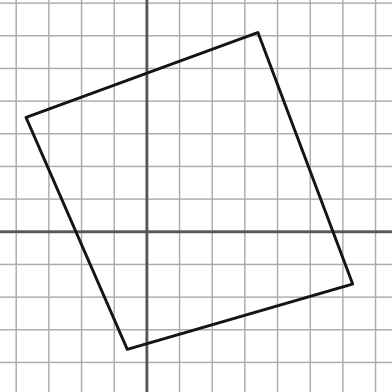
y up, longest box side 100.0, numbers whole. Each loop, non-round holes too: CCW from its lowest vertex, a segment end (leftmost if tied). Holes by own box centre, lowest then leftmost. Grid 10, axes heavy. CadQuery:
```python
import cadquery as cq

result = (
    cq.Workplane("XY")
    .moveTo(-6.0, -36.0)
    .lineTo(63.0, -16.0)
    .lineTo(34.0, 61.0)
    .lineTo(-37.0, 35.0)
    .close()
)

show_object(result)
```